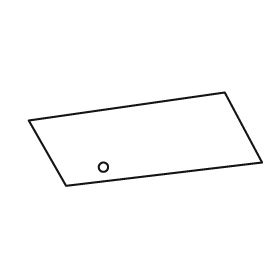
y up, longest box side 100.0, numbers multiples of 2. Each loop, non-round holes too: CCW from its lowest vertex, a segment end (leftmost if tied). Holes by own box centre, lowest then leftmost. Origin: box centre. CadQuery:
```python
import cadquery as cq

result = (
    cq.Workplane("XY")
    .moveTo(-34.0, -20.0)
    .lineTo(50.0, -10.0)
    .lineTo(34.0, 20.0)
    .lineTo(-50.0, 8.0)
    .close()
    .moveTo(-18.0, -12.0)
    .circle(2.0)
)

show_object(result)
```